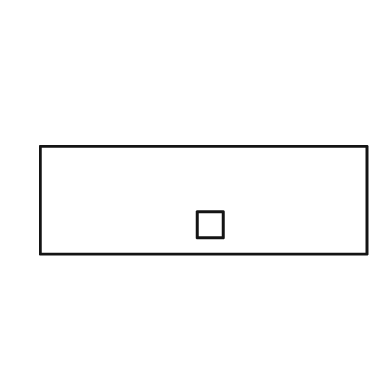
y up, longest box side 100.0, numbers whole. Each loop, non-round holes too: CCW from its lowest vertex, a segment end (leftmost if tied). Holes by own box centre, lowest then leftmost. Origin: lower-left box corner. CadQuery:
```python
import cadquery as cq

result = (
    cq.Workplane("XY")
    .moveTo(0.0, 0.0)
    .lineTo(100.0, 0.0)
    .lineTo(100.0, 33.0)
    .lineTo(0.0, 33.0)
    .close()
    .moveTo(48.0, 5.0)
    .lineTo(56.0, 5.0)
    .lineTo(56.0, 13.0)
    .lineTo(48.0, 13.0)
    .close()
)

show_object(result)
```